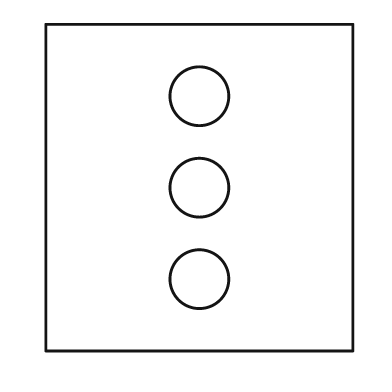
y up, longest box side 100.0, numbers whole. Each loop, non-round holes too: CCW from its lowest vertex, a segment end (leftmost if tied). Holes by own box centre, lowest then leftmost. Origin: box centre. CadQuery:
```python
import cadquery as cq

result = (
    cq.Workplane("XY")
    .moveTo(-47.0, -50.0)
    .lineTo(47.0, -50.0)
    .lineTo(47.0, 50.0)
    .lineTo(-47.0, 50.0)
    .close()
    .moveTo(0.0, -28.0)
    .circle(9.0)
    .moveTo(0.0, 0.0)
    .circle(9.0)
    .moveTo(0.0, 28.0)
    .circle(9.0)
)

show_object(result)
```